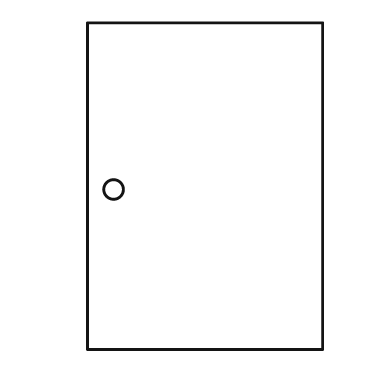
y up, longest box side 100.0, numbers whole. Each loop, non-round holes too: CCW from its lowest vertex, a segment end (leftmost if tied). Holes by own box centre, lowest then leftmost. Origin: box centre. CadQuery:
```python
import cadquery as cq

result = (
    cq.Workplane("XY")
    .moveTo(-36.0, -50.0)
    .lineTo(36.0, -50.0)
    .lineTo(36.0, 50.0)
    .lineTo(-36.0, 50.0)
    .close()
    .moveTo(-28.0, -1.0)
    .circle(3.0)
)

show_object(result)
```